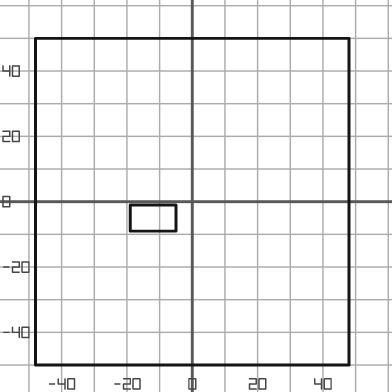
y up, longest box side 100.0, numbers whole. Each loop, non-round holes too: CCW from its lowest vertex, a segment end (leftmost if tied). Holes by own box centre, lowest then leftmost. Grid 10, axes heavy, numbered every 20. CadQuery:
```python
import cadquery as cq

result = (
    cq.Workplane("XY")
    .moveTo(-48.0, -50.0)
    .lineTo(48.0, -50.0)
    .lineTo(48.0, 50.0)
    .lineTo(-48.0, 50.0)
    .close()
    .moveTo(-19.0, -9.0)
    .lineTo(-5.0, -9.0)
    .lineTo(-5.0, -1.0)
    .lineTo(-19.0, -1.0)
    .close()
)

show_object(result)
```